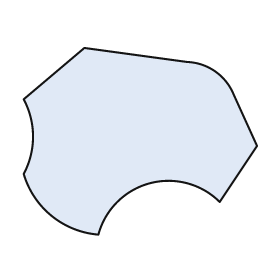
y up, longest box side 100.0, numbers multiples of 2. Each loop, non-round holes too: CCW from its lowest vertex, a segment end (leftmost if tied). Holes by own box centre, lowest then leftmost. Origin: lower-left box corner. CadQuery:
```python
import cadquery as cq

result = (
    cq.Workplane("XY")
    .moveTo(32.0, 0.0)
    .threePointArc((54.0, 22.0), (84.0, 14.0))
    .lineTo(100.0, 38.0)
    .lineTo(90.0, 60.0)
    .threePointArc((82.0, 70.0), (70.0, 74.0))
    .lineTo(26.0, 80.0)
    .lineTo(0.0, 58.0)
    .threePointArc((4.0, 42.0), (0.0, 26.0))
    .threePointArc((12.0, 8.0), (32.0, 0.0))
    .close()
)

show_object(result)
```